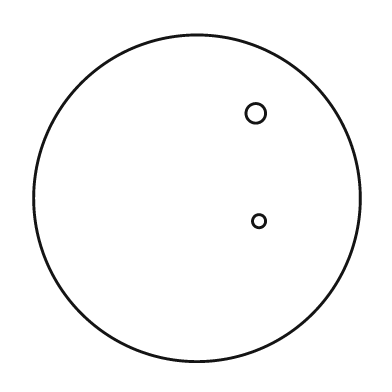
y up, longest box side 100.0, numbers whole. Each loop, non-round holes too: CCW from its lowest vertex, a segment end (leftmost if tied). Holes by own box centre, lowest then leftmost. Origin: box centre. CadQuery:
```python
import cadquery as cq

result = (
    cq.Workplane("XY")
    .moveTo(0.0, 0.0)
    .circle(50.0)
    .moveTo(19.0, -7.0)
    .circle(2.0)
    .moveTo(18.0, 26.0)
    .circle(3.0)
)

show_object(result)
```